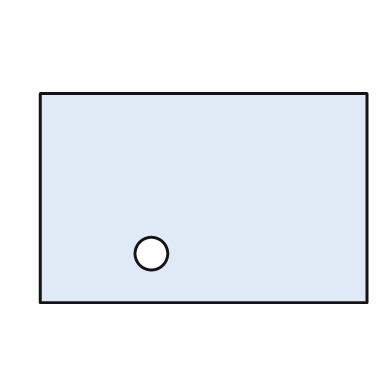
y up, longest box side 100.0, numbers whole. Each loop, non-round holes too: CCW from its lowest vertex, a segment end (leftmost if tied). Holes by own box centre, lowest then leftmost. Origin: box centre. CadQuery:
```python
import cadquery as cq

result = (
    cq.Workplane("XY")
    .moveTo(-50.0, -32.0)
    .lineTo(50.0, -32.0)
    .lineTo(50.0, 32.0)
    .lineTo(-50.0, 32.0)
    .close()
    .moveTo(-16.0, -17.0)
    .circle(5.0)
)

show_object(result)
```